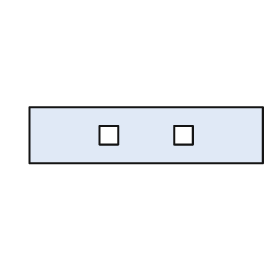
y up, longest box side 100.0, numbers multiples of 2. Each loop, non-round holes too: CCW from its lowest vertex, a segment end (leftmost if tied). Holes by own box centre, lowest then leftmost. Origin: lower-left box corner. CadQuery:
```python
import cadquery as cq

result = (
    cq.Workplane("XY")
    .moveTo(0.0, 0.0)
    .lineTo(100.0, 0.0)
    .lineTo(100.0, 24.0)
    .lineTo(0.0, 24.0)
    .close()
    .moveTo(30.0, 8.0)
    .lineTo(38.0, 8.0)
    .lineTo(38.0, 16.0)
    .lineTo(30.0, 16.0)
    .close()
    .moveTo(62.0, 8.0)
    .lineTo(70.0, 8.0)
    .lineTo(70.0, 16.0)
    .lineTo(62.0, 16.0)
    .close()
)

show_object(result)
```